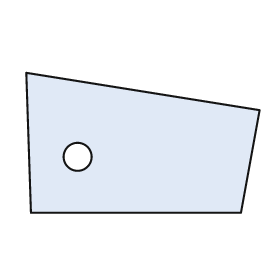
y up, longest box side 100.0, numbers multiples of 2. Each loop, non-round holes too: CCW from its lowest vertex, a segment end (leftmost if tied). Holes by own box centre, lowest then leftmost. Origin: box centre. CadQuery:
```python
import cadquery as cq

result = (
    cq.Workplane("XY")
    .moveTo(-48.0, -30.0)
    .lineTo(42.0, -30.0)
    .lineTo(50.0, 14.0)
    .lineTo(-50.0, 30.0)
    .close()
    .moveTo(-28.0, -6.0)
    .circle(6.0)
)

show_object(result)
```